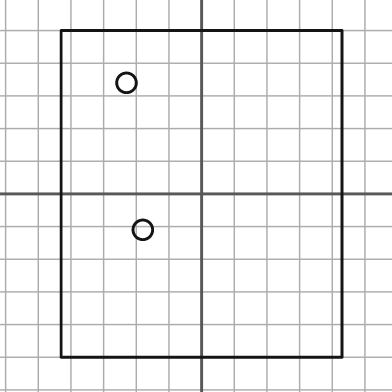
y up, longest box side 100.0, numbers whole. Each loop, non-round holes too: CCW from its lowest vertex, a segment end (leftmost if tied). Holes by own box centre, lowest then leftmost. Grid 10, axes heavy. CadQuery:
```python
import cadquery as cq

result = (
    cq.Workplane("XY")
    .moveTo(-43.0, -50.0)
    .lineTo(43.0, -50.0)
    .lineTo(43.0, 50.0)
    .lineTo(-43.0, 50.0)
    .close()
    .moveTo(-18.0, -11.0)
    .circle(3.0)
    .moveTo(-23.0, 34.0)
    .circle(3.0)
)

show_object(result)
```